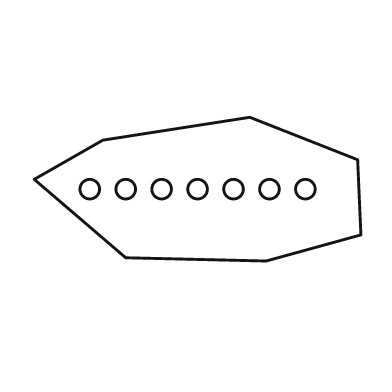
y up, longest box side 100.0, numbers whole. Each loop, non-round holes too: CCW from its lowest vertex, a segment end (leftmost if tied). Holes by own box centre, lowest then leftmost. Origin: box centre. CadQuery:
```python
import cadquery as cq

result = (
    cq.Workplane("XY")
    .moveTo(21.0, -22.0)
    .lineTo(50.0, -14.0)
    .lineTo(49.0, 9.0)
    .lineTo(16.0, 22.0)
    .lineTo(-29.0, 15.0)
    .lineTo(-50.0, 3.0)
    .lineTo(-22.0, -21.0)
    .close()
    .moveTo(-33.0, 0.0)
    .circle(3.0)
    .moveTo(-22.0, 0.0)
    .circle(3.0)
    .moveTo(-11.0, 0.0)
    .circle(3.0)
    .moveTo(0.0, 0.0)
    .circle(3.0)
    .moveTo(11.0, 0.0)
    .circle(3.0)
    .moveTo(22.0, 0.0)
    .circle(3.0)
    .moveTo(33.0, 0.0)
    .circle(3.0)
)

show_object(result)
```